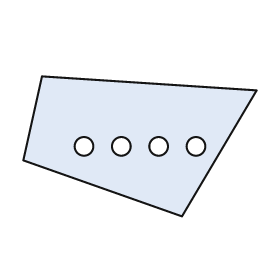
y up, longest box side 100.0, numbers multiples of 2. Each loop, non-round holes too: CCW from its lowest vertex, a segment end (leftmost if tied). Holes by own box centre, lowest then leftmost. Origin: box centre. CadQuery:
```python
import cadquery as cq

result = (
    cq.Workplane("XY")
    .moveTo(18.0, -30.0)
    .lineTo(50.0, 24.0)
    .lineTo(-42.0, 30.0)
    .lineTo(-50.0, -6.0)
    .close()
    .moveTo(-24.0, 0.0)
    .circle(4.0)
    .moveTo(-8.0, 0.0)
    .circle(4.0)
    .moveTo(8.0, 0.0)
    .circle(4.0)
    .moveTo(24.0, 0.0)
    .circle(4.0)
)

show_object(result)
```